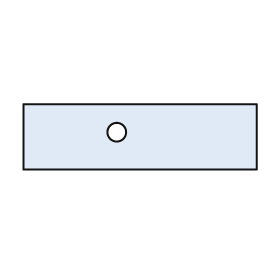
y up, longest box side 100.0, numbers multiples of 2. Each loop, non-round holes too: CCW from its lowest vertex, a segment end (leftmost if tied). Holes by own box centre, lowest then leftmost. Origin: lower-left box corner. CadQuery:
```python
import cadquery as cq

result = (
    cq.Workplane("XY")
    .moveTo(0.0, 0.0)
    .lineTo(100.0, 0.0)
    .lineTo(100.0, 28.0)
    .lineTo(0.0, 28.0)
    .close()
    .moveTo(40.0, 16.0)
    .circle(4.0)
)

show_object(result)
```